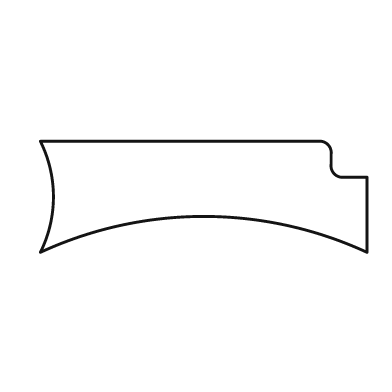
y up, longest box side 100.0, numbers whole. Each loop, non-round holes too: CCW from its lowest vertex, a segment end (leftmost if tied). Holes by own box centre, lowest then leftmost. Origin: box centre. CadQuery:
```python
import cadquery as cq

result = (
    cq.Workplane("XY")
    .moveTo(-50.0, -17.0)
    .threePointArc((0.0, -6.0), (50.0, -17.0))
    .lineTo(50.0, 6.0)
    .lineTo(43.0, 6.0)
    .threePointArc((40.0, 7.0), (39.0, 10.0))
    .lineTo(39.0, 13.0)
    .threePointArc((38.0, 16.0), (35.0, 17.0))
    .lineTo(-50.0, 17.0)
    .threePointArc((-46.0, 0.0), (-50.0, -17.0))
    .close()
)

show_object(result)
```